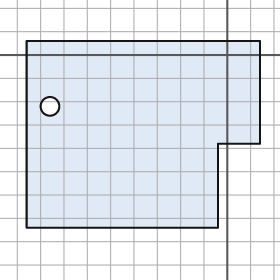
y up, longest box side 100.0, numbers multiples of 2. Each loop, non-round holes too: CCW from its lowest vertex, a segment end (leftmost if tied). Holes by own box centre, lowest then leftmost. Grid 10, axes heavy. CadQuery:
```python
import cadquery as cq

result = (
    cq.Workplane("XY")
    .moveTo(-86.0, -74.0)
    .lineTo(-4.0, -74.0)
    .lineTo(-4.0, -38.0)
    .lineTo(14.0, -38.0)
    .lineTo(14.0, 6.0)
    .lineTo(-86.0, 6.0)
    .close()
    .moveTo(-76.0, -22.0)
    .circle(4.0)
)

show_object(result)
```